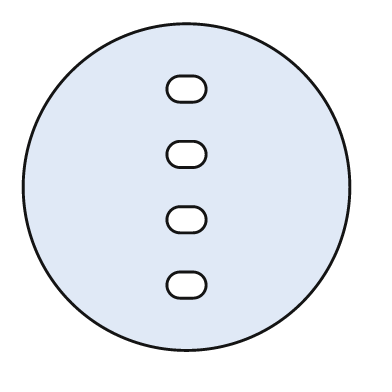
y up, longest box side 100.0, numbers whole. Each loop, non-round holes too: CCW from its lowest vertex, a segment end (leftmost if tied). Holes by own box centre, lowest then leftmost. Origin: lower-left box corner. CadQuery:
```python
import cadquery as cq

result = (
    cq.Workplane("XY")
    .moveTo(50.0, 50.0)
    .circle(50.0)
    .moveTo(48.0, 16.0)
    .lineTo(52.0, 16.0)
    .threePointArc((56.0, 20.0), (52.0, 24.0))
    .lineTo(48.0, 24.0)
    .threePointArc((44.0, 20.0), (48.0, 16.0))
    .close()
    .moveTo(48.0, 36.0)
    .lineTo(52.0, 36.0)
    .threePointArc((56.0, 40.0), (52.0, 44.0))
    .lineTo(48.0, 44.0)
    .threePointArc((44.0, 40.0), (48.0, 36.0))
    .close()
    .moveTo(48.0, 56.0)
    .lineTo(52.0, 56.0)
    .threePointArc((56.0, 60.0), (52.0, 64.0))
    .lineTo(48.0, 64.0)
    .threePointArc((44.0, 60.0), (48.0, 56.0))
    .close()
    .moveTo(48.0, 76.0)
    .lineTo(52.0, 76.0)
    .threePointArc((56.0, 80.0), (52.0, 84.0))
    .lineTo(48.0, 84.0)
    .threePointArc((44.0, 80.0), (48.0, 76.0))
    .close()
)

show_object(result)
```